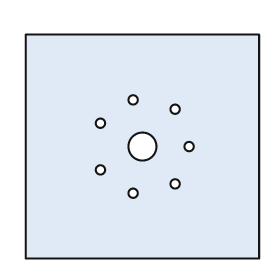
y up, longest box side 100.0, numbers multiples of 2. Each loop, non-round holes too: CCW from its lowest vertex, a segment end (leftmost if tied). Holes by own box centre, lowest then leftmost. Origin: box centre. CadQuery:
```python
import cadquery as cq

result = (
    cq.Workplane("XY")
    .moveTo(-50.0, -48.0)
    .lineTo(50.0, -48.0)
    .lineTo(50.0, 48.0)
    .lineTo(-50.0, 48.0)
    .close()
    .moveTo(-4.0, -20.0)
    .circle(2.0)
    .moveTo(14.0, -16.0)
    .circle(2.0)
    .moveTo(-18.0, -10.0)
    .circle(2.0)
    .moveTo(0.0, 0.0)
    .circle(6.0)
    .moveTo(20.0, 0.0)
    .circle(2.0)
    .moveTo(-18.0, 10.0)
    .circle(2.0)
    .moveTo(14.0, 16.0)
    .circle(2.0)
    .moveTo(-4.0, 20.0)
    .circle(2.0)
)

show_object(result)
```